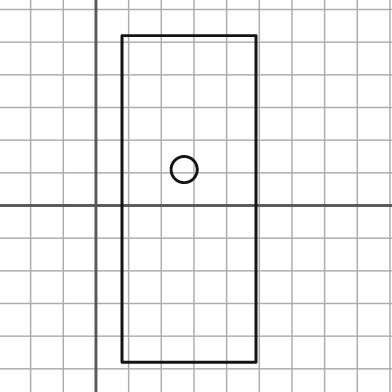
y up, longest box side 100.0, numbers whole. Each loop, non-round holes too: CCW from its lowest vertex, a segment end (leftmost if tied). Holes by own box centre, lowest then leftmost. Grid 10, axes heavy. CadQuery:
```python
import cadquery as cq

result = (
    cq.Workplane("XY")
    .moveTo(8.0, -48.0)
    .lineTo(49.0, -48.0)
    .lineTo(49.0, 52.0)
    .lineTo(8.0, 52.0)
    .close()
    .moveTo(27.0, 11.0)
    .circle(4.0)
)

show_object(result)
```